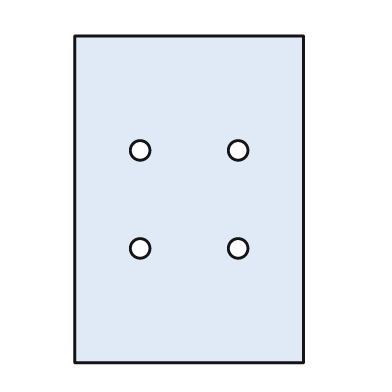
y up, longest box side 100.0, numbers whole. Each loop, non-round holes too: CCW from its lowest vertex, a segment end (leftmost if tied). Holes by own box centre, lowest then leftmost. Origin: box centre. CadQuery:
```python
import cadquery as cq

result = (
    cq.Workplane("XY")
    .moveTo(-35.0, -50.0)
    .lineTo(35.0, -50.0)
    .lineTo(35.0, 50.0)
    .lineTo(-35.0, 50.0)
    .close()
    .moveTo(-15.0, -15.0)
    .circle(3.0)
    .moveTo(15.0, -15.0)
    .circle(3.0)
    .moveTo(-15.0, 15.0)
    .circle(3.0)
    .moveTo(15.0, 15.0)
    .circle(3.0)
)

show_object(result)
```